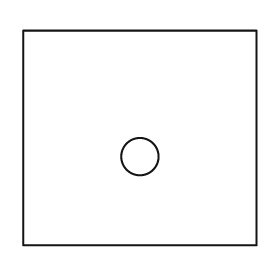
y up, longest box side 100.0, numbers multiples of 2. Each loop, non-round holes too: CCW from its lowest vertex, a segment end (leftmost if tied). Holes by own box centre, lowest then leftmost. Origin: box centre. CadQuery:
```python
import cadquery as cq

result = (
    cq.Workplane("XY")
    .moveTo(-50.0, -46.0)
    .lineTo(50.0, -46.0)
    .lineTo(50.0, 46.0)
    .lineTo(-50.0, 46.0)
    .close()
    .moveTo(0.0, -8.0)
    .circle(8.0)
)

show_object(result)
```